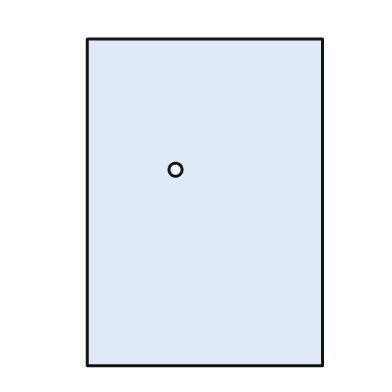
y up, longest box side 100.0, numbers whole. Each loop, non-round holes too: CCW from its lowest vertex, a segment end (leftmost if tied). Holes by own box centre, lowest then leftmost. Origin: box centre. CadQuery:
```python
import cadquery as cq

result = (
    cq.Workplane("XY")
    .moveTo(-36.0, -50.0)
    .lineTo(36.0, -50.0)
    .lineTo(36.0, 50.0)
    .lineTo(-36.0, 50.0)
    .close()
    .moveTo(-9.0, 10.0)
    .circle(2.0)
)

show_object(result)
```